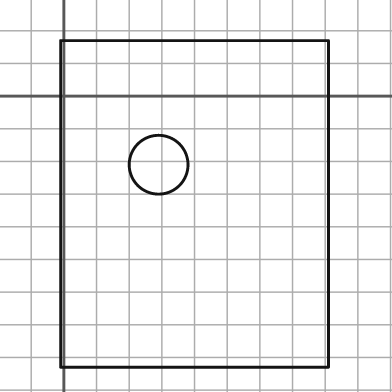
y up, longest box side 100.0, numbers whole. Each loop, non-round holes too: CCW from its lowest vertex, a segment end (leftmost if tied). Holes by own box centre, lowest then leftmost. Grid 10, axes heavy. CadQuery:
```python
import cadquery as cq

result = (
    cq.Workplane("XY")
    .moveTo(-1.0, -83.0)
    .lineTo(81.0, -83.0)
    .lineTo(81.0, 17.0)
    .lineTo(-1.0, 17.0)
    .close()
    .moveTo(29.0, -21.0)
    .circle(9.0)
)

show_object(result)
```